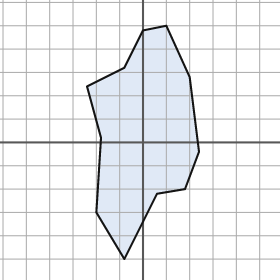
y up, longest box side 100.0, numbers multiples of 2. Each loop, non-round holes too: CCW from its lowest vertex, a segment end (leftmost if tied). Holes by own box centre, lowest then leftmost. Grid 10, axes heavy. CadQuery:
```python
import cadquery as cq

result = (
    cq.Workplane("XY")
    .moveTo(-8.0, -50.0)
    .lineTo(6.0, -22.0)
    .lineTo(18.0, -20.0)
    .lineTo(24.0, -4.0)
    .lineTo(20.0, 28.0)
    .lineTo(10.0, 50.0)
    .lineTo(0.0, 48.0)
    .lineTo(-8.0, 32.0)
    .lineTo(-24.0, 24.0)
    .lineTo(-18.0, 2.0)
    .lineTo(-20.0, -30.0)
    .close()
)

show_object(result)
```